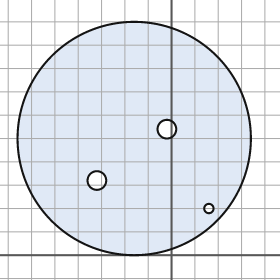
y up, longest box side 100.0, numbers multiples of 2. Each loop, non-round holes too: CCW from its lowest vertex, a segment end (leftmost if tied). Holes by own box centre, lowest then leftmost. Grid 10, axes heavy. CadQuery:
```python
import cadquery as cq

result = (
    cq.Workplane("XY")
    .moveTo(-16.0, 50.0)
    .circle(50.0)
    .moveTo(16.0, 20.0)
    .circle(2.0)
    .moveTo(-32.0, 32.0)
    .circle(4.0)
    .moveTo(-2.0, 54.0)
    .circle(4.0)
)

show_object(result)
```